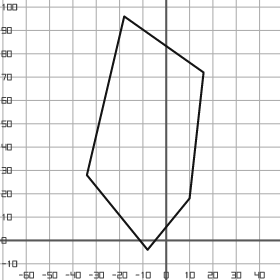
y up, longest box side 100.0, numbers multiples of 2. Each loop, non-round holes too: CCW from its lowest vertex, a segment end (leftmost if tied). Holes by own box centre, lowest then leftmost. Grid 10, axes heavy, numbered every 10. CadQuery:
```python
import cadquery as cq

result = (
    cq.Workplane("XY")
    .moveTo(-8.0, -4.0)
    .lineTo(10.0, 18.0)
    .lineTo(16.0, 72.0)
    .lineTo(-18.0, 96.0)
    .lineTo(-34.0, 28.0)
    .close()
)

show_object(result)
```